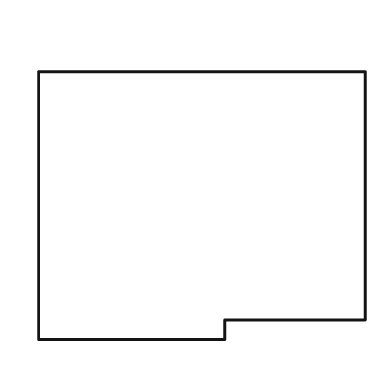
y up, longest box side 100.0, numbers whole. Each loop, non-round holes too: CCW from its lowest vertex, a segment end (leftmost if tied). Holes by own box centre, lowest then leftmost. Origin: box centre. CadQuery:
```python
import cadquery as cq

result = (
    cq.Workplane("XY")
    .moveTo(-50.0, -41.0)
    .lineTo(7.0, -41.0)
    .lineTo(7.0, -35.0)
    .lineTo(50.0, -35.0)
    .lineTo(50.0, 41.0)
    .lineTo(-50.0, 41.0)
    .close()
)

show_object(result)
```